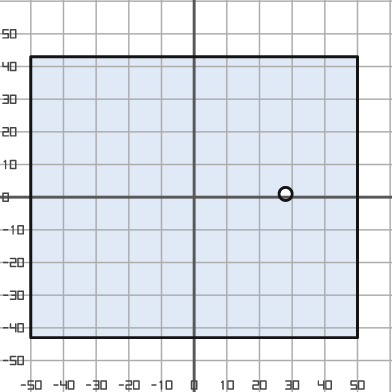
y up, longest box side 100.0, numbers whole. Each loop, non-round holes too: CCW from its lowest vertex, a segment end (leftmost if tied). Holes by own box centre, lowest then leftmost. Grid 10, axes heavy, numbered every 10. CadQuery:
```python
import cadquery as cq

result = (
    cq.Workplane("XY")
    .moveTo(-50.0, -43.0)
    .lineTo(50.0, -43.0)
    .lineTo(50.0, 43.0)
    .lineTo(-50.0, 43.0)
    .close()
    .moveTo(28.0, 1.0)
    .circle(2.0)
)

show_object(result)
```